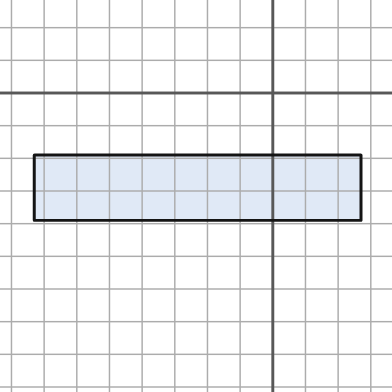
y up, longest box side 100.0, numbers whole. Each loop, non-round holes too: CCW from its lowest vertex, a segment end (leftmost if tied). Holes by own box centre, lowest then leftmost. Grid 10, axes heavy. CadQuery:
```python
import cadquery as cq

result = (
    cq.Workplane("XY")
    .moveTo(-73.0, -39.0)
    .lineTo(27.0, -39.0)
    .lineTo(27.0, -19.0)
    .lineTo(-73.0, -19.0)
    .close()
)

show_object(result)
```